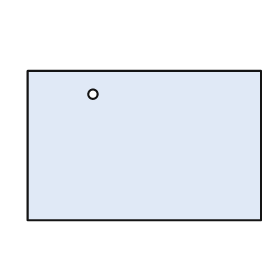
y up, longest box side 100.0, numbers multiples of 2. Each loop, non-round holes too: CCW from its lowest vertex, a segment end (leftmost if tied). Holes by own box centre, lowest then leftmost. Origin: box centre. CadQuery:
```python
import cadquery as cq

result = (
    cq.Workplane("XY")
    .moveTo(-50.0, -32.0)
    .lineTo(50.0, -32.0)
    .lineTo(50.0, 32.0)
    .lineTo(-50.0, 32.0)
    .close()
    .moveTo(-22.0, 22.0)
    .circle(2.0)
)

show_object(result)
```